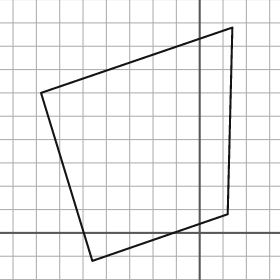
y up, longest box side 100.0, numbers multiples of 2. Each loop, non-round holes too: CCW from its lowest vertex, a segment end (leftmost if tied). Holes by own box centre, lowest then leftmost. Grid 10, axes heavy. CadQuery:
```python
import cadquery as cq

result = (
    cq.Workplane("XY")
    .moveTo(-46.0, -12.0)
    .lineTo(12.0, 8.0)
    .lineTo(14.0, 88.0)
    .lineTo(-68.0, 60.0)
    .close()
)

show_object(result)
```